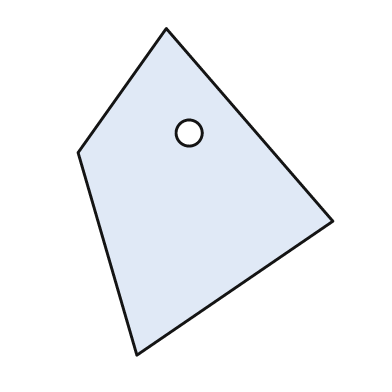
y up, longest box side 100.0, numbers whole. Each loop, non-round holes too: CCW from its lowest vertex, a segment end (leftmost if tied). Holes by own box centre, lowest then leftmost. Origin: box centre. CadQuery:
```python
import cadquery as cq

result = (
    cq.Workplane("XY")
    .moveTo(-21.0, -50.0)
    .lineTo(39.0, -9.0)
    .lineTo(-12.0, 50.0)
    .lineTo(-39.0, 12.0)
    .close()
    .moveTo(-5.0, 18.0)
    .circle(4.0)
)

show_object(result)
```